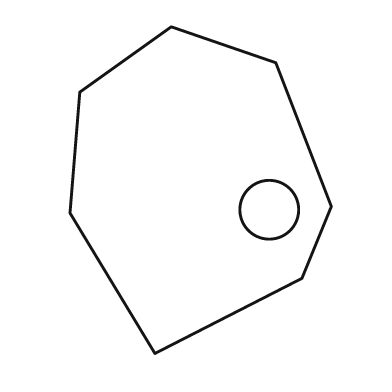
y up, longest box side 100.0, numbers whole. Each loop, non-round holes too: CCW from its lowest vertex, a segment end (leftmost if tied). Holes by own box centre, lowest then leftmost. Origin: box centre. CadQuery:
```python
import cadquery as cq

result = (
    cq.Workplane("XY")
    .moveTo(-14.0, -50.0)
    .lineTo(31.0, -27.0)
    .lineTo(40.0, -5.0)
    .lineTo(23.0, 39.0)
    .lineTo(-9.0, 50.0)
    .lineTo(-37.0, 30.0)
    .lineTo(-40.0, -7.0)
    .close()
    .moveTo(21.0, -6.0)
    .circle(9.0)
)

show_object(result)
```